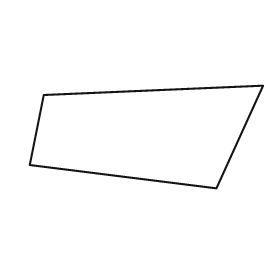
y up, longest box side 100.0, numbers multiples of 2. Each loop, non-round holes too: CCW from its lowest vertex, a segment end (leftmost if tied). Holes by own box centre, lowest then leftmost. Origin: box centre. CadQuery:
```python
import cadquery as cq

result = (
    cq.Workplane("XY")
    .moveTo(30.0, -22.0)
    .lineTo(50.0, 22.0)
    .lineTo(-44.0, 18.0)
    .lineTo(-50.0, -12.0)
    .close()
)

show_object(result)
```